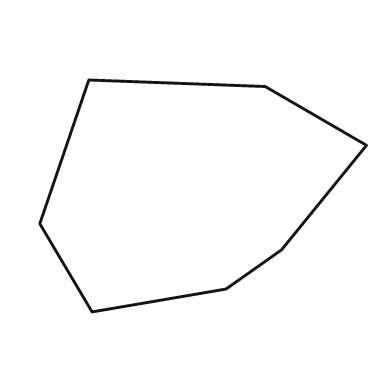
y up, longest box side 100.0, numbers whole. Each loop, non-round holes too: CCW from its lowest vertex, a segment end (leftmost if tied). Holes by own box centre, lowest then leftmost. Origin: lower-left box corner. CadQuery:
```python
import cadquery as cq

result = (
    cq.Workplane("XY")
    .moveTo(16.0, 0.0)
    .lineTo(57.0, 7.0)
    .lineTo(74.0, 19.0)
    .lineTo(100.0, 51.0)
    .lineTo(69.0, 69.0)
    .lineTo(15.0, 71.0)
    .lineTo(0.0, 27.0)
    .close()
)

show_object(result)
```